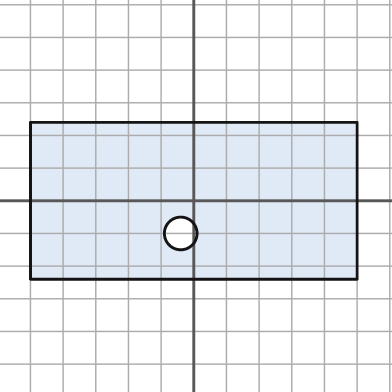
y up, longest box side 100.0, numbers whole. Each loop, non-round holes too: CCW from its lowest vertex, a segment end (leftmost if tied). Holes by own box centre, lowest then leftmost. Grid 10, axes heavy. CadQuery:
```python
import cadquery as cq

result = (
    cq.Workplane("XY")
    .moveTo(-50.0, -24.0)
    .lineTo(50.0, -24.0)
    .lineTo(50.0, 24.0)
    .lineTo(-50.0, 24.0)
    .close()
    .moveTo(-4.0, -10.0)
    .circle(5.0)
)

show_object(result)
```